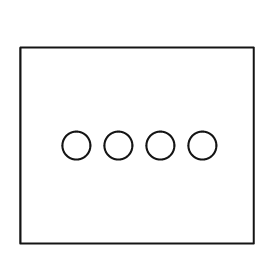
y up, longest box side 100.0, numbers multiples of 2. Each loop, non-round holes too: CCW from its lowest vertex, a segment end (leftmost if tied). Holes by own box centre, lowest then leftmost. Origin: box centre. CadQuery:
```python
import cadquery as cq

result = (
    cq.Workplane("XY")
    .moveTo(-50.0, -42.0)
    .lineTo(50.0, -42.0)
    .lineTo(50.0, 42.0)
    .lineTo(-50.0, 42.0)
    .close()
    .moveTo(-26.0, 0.0)
    .circle(6.0)
    .moveTo(-8.0, 0.0)
    .circle(6.0)
    .moveTo(10.0, 0.0)
    .circle(6.0)
    .moveTo(28.0, 0.0)
    .circle(6.0)
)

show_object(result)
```